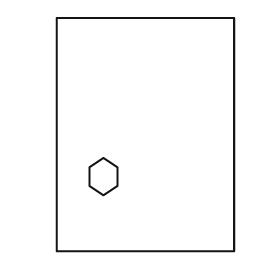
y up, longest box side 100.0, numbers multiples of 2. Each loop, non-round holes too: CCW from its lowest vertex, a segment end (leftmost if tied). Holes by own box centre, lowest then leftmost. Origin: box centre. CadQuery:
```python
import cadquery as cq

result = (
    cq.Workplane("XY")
    .moveTo(-38.0, -50.0)
    .lineTo(38.0, -50.0)
    .lineTo(38.0, 50.0)
    .lineTo(-38.0, 50.0)
    .close()
    .moveTo(-18.0, -26.0)
    .lineTo(-12.0, -22.0)
    .lineTo(-12.0, -14.0)
    .lineTo(-18.0, -10.0)
    .lineTo(-24.0, -14.0)
    .lineTo(-24.0, -22.0)
    .close()
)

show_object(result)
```